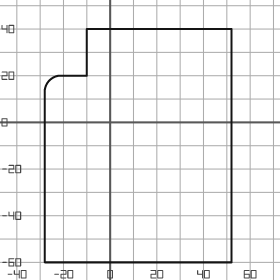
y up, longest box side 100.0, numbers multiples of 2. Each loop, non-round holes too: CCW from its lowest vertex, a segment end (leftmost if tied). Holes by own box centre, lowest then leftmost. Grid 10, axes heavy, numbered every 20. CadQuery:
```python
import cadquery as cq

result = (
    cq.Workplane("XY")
    .moveTo(-28.0, -60.0)
    .lineTo(52.0, -60.0)
    .lineTo(52.0, 40.0)
    .lineTo(-10.0, 40.0)
    .lineTo(-10.0, 20.0)
    .lineTo(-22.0, 20.0)
    .threePointArc((-26.0, 18.0), (-28.0, 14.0))
    .close()
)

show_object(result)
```